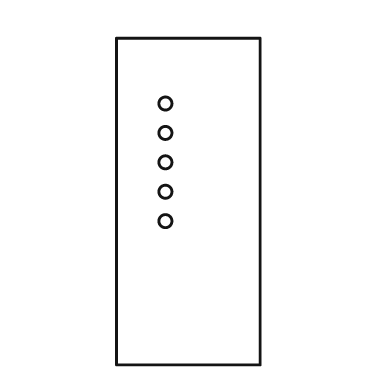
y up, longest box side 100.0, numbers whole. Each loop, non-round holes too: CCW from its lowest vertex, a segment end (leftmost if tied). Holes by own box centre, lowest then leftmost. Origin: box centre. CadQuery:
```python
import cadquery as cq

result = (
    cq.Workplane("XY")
    .moveTo(-22.0, -50.0)
    .lineTo(22.0, -50.0)
    .lineTo(22.0, 50.0)
    .lineTo(-22.0, 50.0)
    .close()
    .moveTo(-7.0, -6.0)
    .circle(2.0)
    .moveTo(-7.0, 3.0)
    .circle(2.0)
    .moveTo(-7.0, 12.0)
    .circle(2.0)
    .moveTo(-7.0, 21.0)
    .circle(2.0)
    .moveTo(-7.0, 30.0)
    .circle(2.0)
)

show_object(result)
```